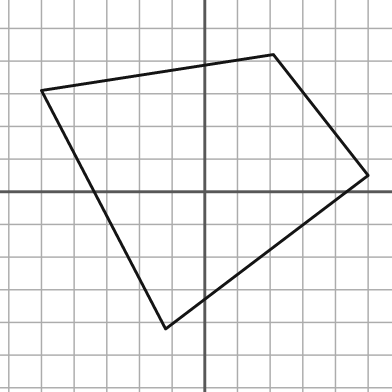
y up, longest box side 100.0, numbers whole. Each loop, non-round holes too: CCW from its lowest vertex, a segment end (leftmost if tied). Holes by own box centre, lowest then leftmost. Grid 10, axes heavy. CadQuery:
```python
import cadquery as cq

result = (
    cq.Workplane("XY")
    .moveTo(-12.0, -42.0)
    .lineTo(50.0, 5.0)
    .lineTo(21.0, 42.0)
    .lineTo(-50.0, 31.0)
    .close()
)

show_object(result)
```